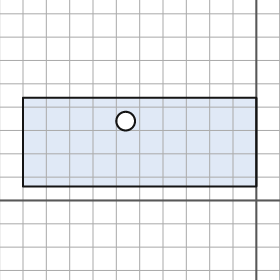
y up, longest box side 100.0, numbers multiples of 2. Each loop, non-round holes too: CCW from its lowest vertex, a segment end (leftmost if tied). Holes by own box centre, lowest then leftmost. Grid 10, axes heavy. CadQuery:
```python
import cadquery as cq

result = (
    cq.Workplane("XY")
    .moveTo(-100.0, 6.0)
    .lineTo(0.0, 6.0)
    .lineTo(0.0, 44.0)
    .lineTo(-100.0, 44.0)
    .close()
    .moveTo(-56.0, 34.0)
    .circle(4.0)
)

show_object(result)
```